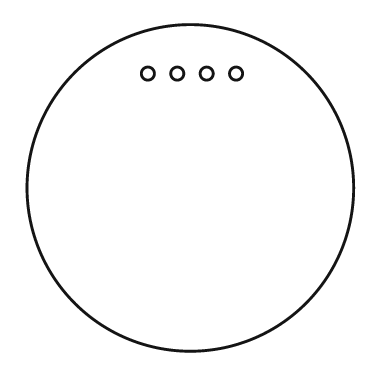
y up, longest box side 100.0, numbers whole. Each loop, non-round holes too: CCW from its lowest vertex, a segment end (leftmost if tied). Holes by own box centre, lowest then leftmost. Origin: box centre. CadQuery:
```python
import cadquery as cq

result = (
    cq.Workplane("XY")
    .moveTo(0.0, 0.0)
    .circle(50.0)
    .moveTo(-13.0, 35.0)
    .circle(2.0)
    .moveTo(-4.0, 35.0)
    .circle(2.0)
    .moveTo(5.0, 35.0)
    .circle(2.0)
    .moveTo(14.0, 35.0)
    .circle(2.0)
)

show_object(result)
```